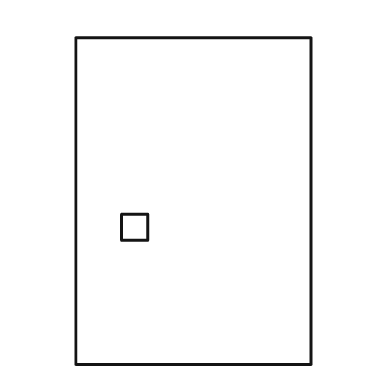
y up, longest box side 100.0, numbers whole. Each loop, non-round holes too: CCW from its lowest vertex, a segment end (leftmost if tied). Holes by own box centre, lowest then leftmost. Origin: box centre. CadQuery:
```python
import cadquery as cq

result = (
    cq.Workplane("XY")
    .moveTo(-36.0, -50.0)
    .lineTo(36.0, -50.0)
    .lineTo(36.0, 50.0)
    .lineTo(-36.0, 50.0)
    .close()
    .moveTo(-22.0, -12.0)
    .lineTo(-14.0, -12.0)
    .lineTo(-14.0, -4.0)
    .lineTo(-22.0, -4.0)
    .close()
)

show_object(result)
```